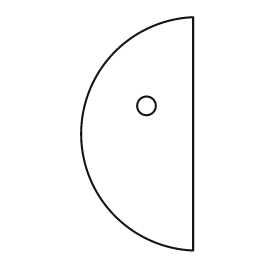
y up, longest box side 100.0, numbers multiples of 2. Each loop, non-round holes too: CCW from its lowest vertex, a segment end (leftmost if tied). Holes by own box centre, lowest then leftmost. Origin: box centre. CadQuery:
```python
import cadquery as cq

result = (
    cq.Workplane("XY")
    .moveTo(24.0, -50.0)
    .lineTo(24.0, 50.0)
    .threePointArc((-24.0, 0.0), (24.0, -50.0))
    .close()
    .moveTo(4.0, 12.0)
    .circle(4.0)
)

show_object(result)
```